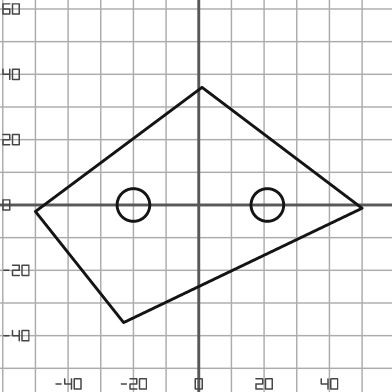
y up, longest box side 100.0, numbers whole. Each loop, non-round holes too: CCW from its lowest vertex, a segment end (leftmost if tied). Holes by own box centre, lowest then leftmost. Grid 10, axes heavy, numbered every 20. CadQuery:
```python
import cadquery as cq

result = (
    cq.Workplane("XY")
    .moveTo(-23.0, -36.0)
    .lineTo(50.0, -1.0)
    .lineTo(1.0, 36.0)
    .lineTo(-50.0, -2.0)
    .close()
    .moveTo(-20.0, 0.0)
    .circle(5.0)
    .moveTo(21.0, 0.0)
    .circle(5.0)
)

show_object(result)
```